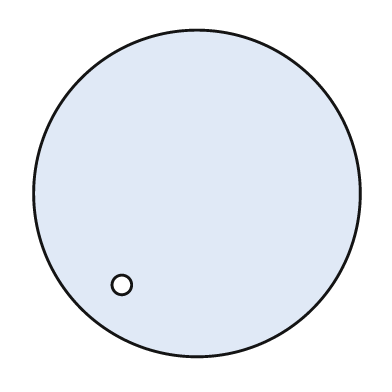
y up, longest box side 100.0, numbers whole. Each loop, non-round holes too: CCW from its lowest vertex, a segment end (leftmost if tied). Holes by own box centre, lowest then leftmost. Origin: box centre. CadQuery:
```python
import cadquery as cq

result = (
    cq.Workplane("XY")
    .moveTo(0.0, 0.0)
    .circle(50.0)
    .moveTo(-23.0, -28.0)
    .circle(3.0)
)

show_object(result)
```